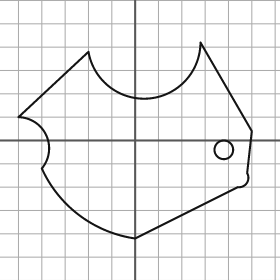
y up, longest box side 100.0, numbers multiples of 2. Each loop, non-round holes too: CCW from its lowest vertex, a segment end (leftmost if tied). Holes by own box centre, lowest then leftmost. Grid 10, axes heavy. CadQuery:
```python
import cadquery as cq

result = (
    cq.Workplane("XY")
    .moveTo(0.0, -42.0)
    .lineTo(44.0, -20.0)
    .threePointArc((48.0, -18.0), (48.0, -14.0))
    .lineTo(50.0, 4.0)
    .lineTo(28.0, 42.0)
    .threePointArc((6.0, 18.0), (-20.0, 38.0))
    .lineTo(-50.0, 10.0)
    .threePointArc((-38.0, 2.0), (-40.0, -12.0))
    .threePointArc((-24.0, -32.0), (0.0, -42.0))
    .close()
    .moveTo(38.0, -4.0)
    .circle(4.0)
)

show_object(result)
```